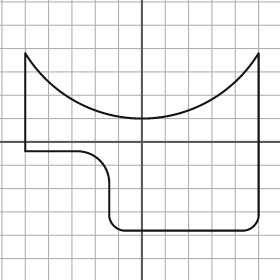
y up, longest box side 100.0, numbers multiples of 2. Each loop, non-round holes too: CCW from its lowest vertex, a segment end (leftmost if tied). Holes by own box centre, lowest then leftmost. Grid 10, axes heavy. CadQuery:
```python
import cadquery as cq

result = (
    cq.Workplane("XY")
    .moveTo(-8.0, -38.0)
    .lineTo(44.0, -38.0)
    .threePointArc((48.0, -36.0), (50.0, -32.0))
    .lineTo(50.0, 38.0)
    .threePointArc((0.0, 10.0), (-50.0, 38.0))
    .lineTo(-50.0, -4.0)
    .lineTo(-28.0, -4.0)
    .threePointArc((-18.0, -8.0), (-14.0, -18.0))
    .lineTo(-14.0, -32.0)
    .threePointArc((-12.0, -36.0), (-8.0, -38.0))
    .close()
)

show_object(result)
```